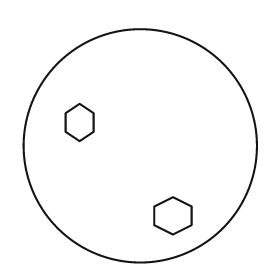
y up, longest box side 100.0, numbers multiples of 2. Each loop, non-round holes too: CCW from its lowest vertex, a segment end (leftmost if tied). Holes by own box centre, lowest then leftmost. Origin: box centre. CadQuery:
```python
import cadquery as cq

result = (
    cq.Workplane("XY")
    .moveTo(0.0, 0.0)
    .circle(50.0)
    .moveTo(14.0, -38.0)
    .lineTo(22.0, -34.0)
    .lineTo(22.0, -26.0)
    .lineTo(14.0, -22.0)
    .lineTo(6.0, -26.0)
    .lineTo(6.0, -34.0)
    .close()
    .moveTo(-26.0, 2.0)
    .lineTo(-20.0, 6.0)
    .lineTo(-20.0, 14.0)
    .lineTo(-26.0, 18.0)
    .lineTo(-32.0, 14.0)
    .lineTo(-32.0, 6.0)
    .close()
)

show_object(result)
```